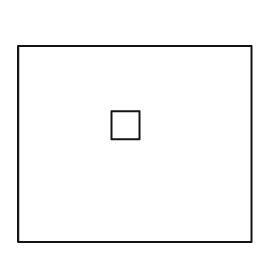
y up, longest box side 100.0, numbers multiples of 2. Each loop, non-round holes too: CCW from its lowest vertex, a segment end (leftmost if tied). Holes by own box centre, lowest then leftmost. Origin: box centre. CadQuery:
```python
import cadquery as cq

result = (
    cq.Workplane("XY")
    .moveTo(-50.0, -42.0)
    .lineTo(50.0, -42.0)
    .lineTo(50.0, 42.0)
    .lineTo(-50.0, 42.0)
    .close()
    .moveTo(-10.0, 2.0)
    .lineTo(2.0, 2.0)
    .lineTo(2.0, 14.0)
    .lineTo(-10.0, 14.0)
    .close()
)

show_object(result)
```